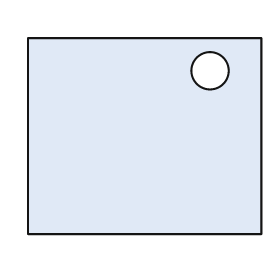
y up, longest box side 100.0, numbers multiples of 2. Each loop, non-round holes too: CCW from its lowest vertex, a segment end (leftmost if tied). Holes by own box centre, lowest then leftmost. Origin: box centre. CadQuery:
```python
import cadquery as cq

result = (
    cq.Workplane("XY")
    .moveTo(-50.0, -42.0)
    .lineTo(50.0, -42.0)
    .lineTo(50.0, 42.0)
    .lineTo(-50.0, 42.0)
    .close()
    .moveTo(28.0, 28.0)
    .circle(8.0)
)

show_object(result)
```